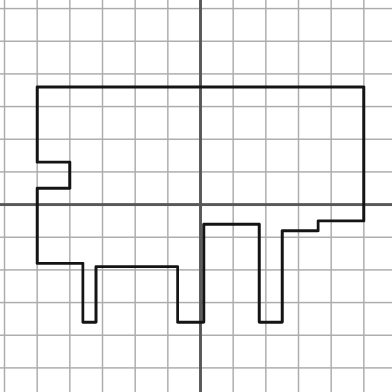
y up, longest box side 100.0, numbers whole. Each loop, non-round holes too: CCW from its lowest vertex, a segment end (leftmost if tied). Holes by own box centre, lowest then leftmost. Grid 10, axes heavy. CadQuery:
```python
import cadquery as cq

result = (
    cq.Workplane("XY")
    .moveTo(-36.0, -36.0)
    .lineTo(-32.0, -36.0)
    .lineTo(-32.0, -19.0)
    .lineTo(-7.0, -19.0)
    .lineTo(-7.0, -36.0)
    .lineTo(1.0, -36.0)
    .lineTo(1.0, -6.0)
    .lineTo(18.0, -6.0)
    .lineTo(18.0, -36.0)
    .lineTo(25.0, -36.0)
    .lineTo(25.0, -8.0)
    .lineTo(36.0, -8.0)
    .lineTo(36.0, -5.0)
    .lineTo(50.0, -5.0)
    .lineTo(50.0, 36.0)
    .lineTo(-50.0, 36.0)
    .lineTo(-50.0, 13.0)
    .lineTo(-40.0, 13.0)
    .lineTo(-40.0, 5.0)
    .lineTo(-50.0, 5.0)
    .lineTo(-50.0, -18.0)
    .lineTo(-36.0, -18.0)
    .close()
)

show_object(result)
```